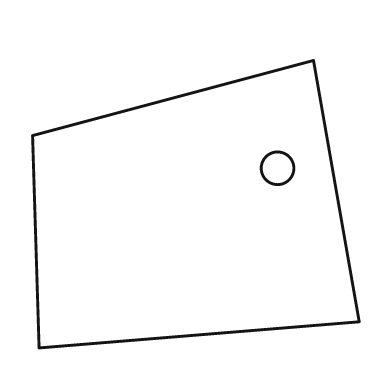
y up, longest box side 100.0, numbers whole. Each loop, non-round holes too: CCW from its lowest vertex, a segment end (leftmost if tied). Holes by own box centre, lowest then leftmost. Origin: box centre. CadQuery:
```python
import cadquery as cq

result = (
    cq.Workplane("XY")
    .moveTo(-48.0, -44.0)
    .lineTo(50.0, -36.0)
    .lineTo(36.0, 44.0)
    .lineTo(-50.0, 21.0)
    .close()
    .moveTo(25.0, 11.0)
    .circle(5.0)
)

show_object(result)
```